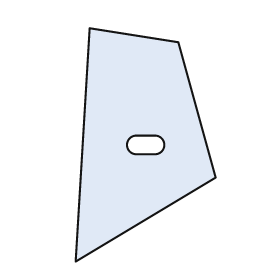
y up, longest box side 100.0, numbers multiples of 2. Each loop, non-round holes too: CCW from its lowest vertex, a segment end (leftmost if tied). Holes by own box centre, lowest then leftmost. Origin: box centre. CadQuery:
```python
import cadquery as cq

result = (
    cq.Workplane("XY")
    .moveTo(-30.0, -50.0)
    .lineTo(30.0, -14.0)
    .lineTo(14.0, 44.0)
    .lineTo(-24.0, 50.0)
    .close()
    .moveTo(-4.0, -4.0)
    .lineTo(4.0, -4.0)
    .threePointArc((8.0, 0.0), (4.0, 4.0))
    .lineTo(-4.0, 4.0)
    .threePointArc((-8.0, 0.0), (-4.0, -4.0))
    .close()
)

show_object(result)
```